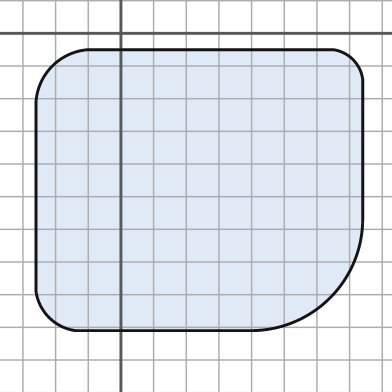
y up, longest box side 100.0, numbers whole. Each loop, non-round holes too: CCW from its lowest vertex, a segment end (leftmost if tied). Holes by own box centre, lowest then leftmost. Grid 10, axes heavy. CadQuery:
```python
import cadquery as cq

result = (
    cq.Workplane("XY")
    .moveTo(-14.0, -91.0)
    .lineTo(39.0, -91.0)
    .threePointArc((64.0, -81.0), (74.0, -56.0))
    .lineTo(74.0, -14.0)
    .threePointArc((71.0, -8.0), (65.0, -5.0))
    .lineTo(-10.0, -5.0)
    .threePointArc((-21.0, -10.0), (-26.0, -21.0))
    .lineTo(-26.0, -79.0)
    .threePointArc((-22.0, -87.0), (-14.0, -91.0))
    .close()
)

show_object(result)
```